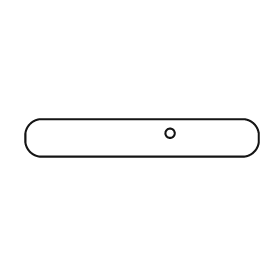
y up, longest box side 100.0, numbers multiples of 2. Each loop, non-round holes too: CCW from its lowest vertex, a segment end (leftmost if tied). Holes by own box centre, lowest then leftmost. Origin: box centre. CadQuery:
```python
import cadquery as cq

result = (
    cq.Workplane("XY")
    .moveTo(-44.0, -8.0)
    .lineTo(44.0, -8.0)
    .threePointArc((48.0, -6.0), (50.0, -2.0))
    .lineTo(50.0, 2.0)
    .threePointArc((48.0, 6.0), (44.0, 8.0))
    .lineTo(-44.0, 8.0)
    .threePointArc((-48.0, 6.0), (-50.0, 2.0))
    .lineTo(-50.0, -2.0)
    .threePointArc((-48.0, -6.0), (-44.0, -8.0))
    .close()
    .moveTo(12.0, 2.0)
    .circle(2.0)
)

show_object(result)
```